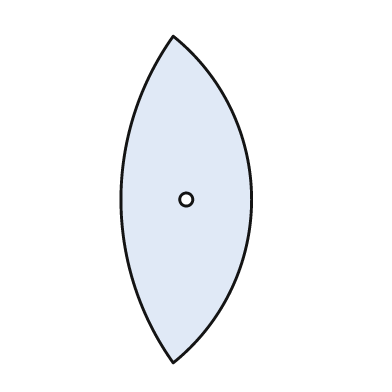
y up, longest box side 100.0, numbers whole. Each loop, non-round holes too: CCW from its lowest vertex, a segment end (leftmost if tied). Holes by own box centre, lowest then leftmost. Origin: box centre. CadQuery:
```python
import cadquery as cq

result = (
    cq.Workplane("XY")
    .moveTo(-4.0, -50.0)
    .threePointArc((20.0, 0.0), (-4.0, 50.0))
    .threePointArc((-20.0, 0.0), (-4.0, -50.0))
    .close()
    .moveTo(0.0, 0.0)
    .circle(2.0)
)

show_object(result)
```